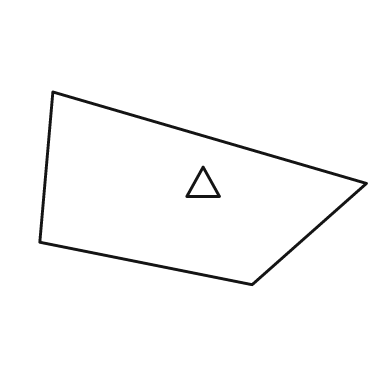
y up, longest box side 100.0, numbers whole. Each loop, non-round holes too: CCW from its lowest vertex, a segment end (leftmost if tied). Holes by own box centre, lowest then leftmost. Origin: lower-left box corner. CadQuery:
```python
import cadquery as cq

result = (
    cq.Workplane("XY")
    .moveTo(65.0, 0.0)
    .lineTo(100.0, 31.0)
    .lineTo(4.0, 59.0)
    .lineTo(0.0, 13.0)
    .close()
    .moveTo(45.0, 27.0)
    .lineTo(55.0, 27.0)
    .lineTo(50.0, 36.0)
    .close()
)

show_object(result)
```